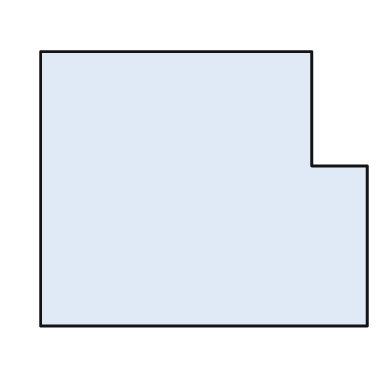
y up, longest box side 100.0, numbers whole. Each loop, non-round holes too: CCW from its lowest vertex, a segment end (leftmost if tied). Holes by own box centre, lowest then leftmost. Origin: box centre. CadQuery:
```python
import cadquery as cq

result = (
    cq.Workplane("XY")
    .moveTo(-50.0, -42.0)
    .lineTo(50.0, -42.0)
    .lineTo(50.0, 7.0)
    .lineTo(33.0, 7.0)
    .lineTo(33.0, 42.0)
    .lineTo(-50.0, 42.0)
    .close()
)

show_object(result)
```